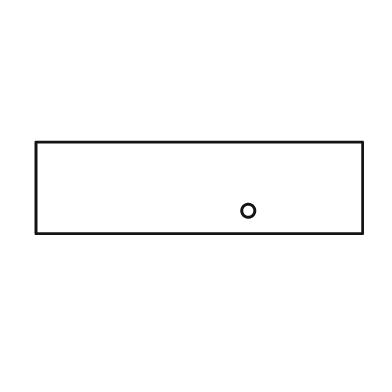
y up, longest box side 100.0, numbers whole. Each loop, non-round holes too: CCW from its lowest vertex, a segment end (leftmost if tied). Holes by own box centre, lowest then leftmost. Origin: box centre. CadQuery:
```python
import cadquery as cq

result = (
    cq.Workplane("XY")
    .moveTo(-50.0, -14.0)
    .lineTo(50.0, -14.0)
    .lineTo(50.0, 14.0)
    .lineTo(-50.0, 14.0)
    .close()
    .moveTo(15.0, -7.0)
    .circle(2.0)
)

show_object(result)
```